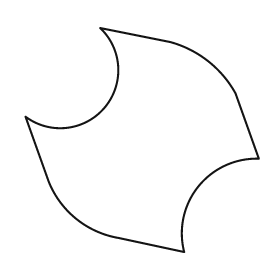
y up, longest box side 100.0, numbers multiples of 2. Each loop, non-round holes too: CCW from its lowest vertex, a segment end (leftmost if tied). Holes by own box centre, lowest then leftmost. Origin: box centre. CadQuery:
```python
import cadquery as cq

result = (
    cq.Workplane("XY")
    .moveTo(18.0, -48.0)
    .threePointArc((24.0, -20.0), (50.0, -8.0))
    .lineTo(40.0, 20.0)
    .threePointArc((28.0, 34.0), (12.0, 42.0))
    .lineTo(-18.0, 48.0)
    .threePointArc((-16.0, 14.0), (-50.0, 10.0))
    .lineTo(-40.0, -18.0)
    .threePointArc((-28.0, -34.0), (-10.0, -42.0))
    .close()
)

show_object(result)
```